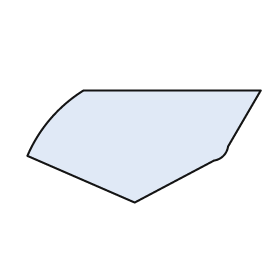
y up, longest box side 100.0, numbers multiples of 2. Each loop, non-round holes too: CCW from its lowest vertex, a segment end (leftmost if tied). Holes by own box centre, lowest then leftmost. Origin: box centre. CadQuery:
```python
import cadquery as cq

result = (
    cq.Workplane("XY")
    .moveTo(-4.0, -24.0)
    .lineTo(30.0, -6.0)
    .threePointArc((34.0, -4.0), (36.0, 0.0))
    .lineTo(50.0, 24.0)
    .lineTo(-26.0, 24.0)
    .threePointArc((-40.0, 12.0), (-50.0, -4.0))
    .close()
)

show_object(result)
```